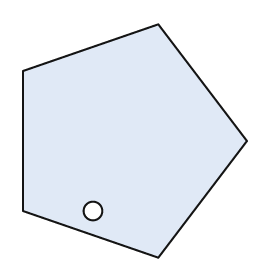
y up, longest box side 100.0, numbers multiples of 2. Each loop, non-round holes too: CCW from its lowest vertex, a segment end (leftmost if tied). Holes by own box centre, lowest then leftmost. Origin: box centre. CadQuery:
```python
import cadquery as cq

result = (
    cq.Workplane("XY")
    .moveTo(10.0, -50.0)
    .lineTo(48.0, 0.0)
    .lineTo(10.0, 50.0)
    .lineTo(-48.0, 30.0)
    .lineTo(-48.0, -30.0)
    .close()
    .moveTo(-18.0, -30.0)
    .circle(4.0)
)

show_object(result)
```